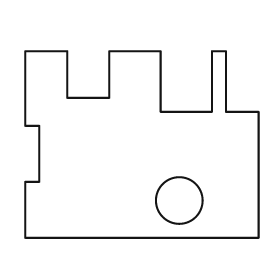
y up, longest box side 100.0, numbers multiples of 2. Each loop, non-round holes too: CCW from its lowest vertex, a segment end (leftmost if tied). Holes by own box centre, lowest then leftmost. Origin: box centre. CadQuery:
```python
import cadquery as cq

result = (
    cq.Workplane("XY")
    .moveTo(-50.0, -40.0)
    .lineTo(50.0, -40.0)
    .lineTo(50.0, 14.0)
    .lineTo(36.0, 14.0)
    .lineTo(36.0, 40.0)
    .lineTo(30.0, 40.0)
    .lineTo(30.0, 14.0)
    .lineTo(8.0, 14.0)
    .lineTo(8.0, 40.0)
    .lineTo(-14.0, 40.0)
    .lineTo(-14.0, 20.0)
    .lineTo(-32.0, 20.0)
    .lineTo(-32.0, 40.0)
    .lineTo(-50.0, 40.0)
    .lineTo(-50.0, 8.0)
    .lineTo(-44.0, 8.0)
    .lineTo(-44.0, -16.0)
    .lineTo(-50.0, -16.0)
    .close()
    .moveTo(16.0, -24.0)
    .circle(10.0)
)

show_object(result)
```